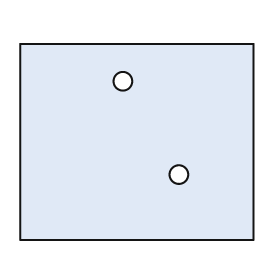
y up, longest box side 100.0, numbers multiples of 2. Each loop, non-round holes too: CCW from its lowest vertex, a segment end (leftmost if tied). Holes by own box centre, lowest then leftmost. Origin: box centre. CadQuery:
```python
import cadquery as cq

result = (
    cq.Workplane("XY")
    .moveTo(-50.0, -42.0)
    .lineTo(50.0, -42.0)
    .lineTo(50.0, 42.0)
    .lineTo(-50.0, 42.0)
    .close()
    .moveTo(18.0, -14.0)
    .circle(4.0)
    .moveTo(-6.0, 26.0)
    .circle(4.0)
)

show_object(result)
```